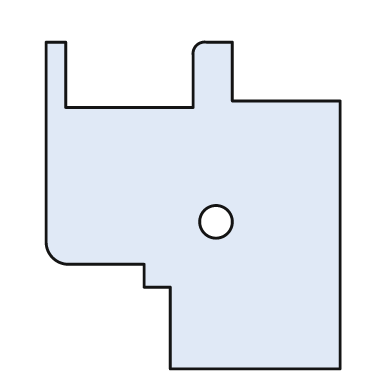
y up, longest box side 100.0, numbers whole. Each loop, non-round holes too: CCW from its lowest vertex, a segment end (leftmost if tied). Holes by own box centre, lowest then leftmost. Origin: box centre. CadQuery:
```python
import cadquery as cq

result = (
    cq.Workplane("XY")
    .moveTo(-7.0, -50.0)
    .lineTo(45.0, -50.0)
    .lineTo(45.0, 32.0)
    .lineTo(12.0, 32.0)
    .lineTo(12.0, 50.0)
    .lineTo(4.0, 50.0)
    .threePointArc((1.0, 49.0), (0.0, 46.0))
    .lineTo(0.0, 30.0)
    .lineTo(-39.0, 30.0)
    .lineTo(-39.0, 50.0)
    .lineTo(-45.0, 50.0)
    .lineTo(-45.0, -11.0)
    .threePointArc((-43.0, -16.0), (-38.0, -18.0))
    .lineTo(-15.0, -18.0)
    .lineTo(-15.0, -25.0)
    .lineTo(-7.0, -25.0)
    .close()
    .moveTo(7.0, -5.0)
    .circle(5.0)
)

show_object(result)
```